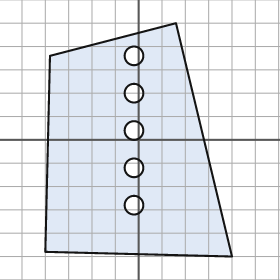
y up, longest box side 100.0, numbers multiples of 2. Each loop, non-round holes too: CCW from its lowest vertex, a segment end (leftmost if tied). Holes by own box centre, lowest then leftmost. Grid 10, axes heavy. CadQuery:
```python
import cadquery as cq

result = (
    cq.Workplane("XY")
    .moveTo(40.0, -50.0)
    .lineTo(16.0, 50.0)
    .lineTo(-38.0, 36.0)
    .lineTo(-40.0, -48.0)
    .close()
    .moveTo(-2.0, -28.0)
    .circle(4.0)
    .moveTo(-2.0, -12.0)
    .circle(4.0)
    .moveTo(-2.0, 4.0)
    .circle(4.0)
    .moveTo(-2.0, 20.0)
    .circle(4.0)
    .moveTo(-2.0, 36.0)
    .circle(4.0)
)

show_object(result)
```